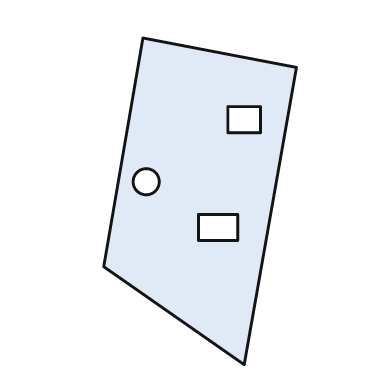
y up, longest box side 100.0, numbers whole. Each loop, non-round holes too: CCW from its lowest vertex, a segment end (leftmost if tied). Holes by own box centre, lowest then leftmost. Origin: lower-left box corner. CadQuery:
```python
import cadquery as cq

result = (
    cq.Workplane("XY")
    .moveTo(43.0, 0.0)
    .lineTo(59.0, 91.0)
    .lineTo(12.0, 100.0)
    .lineTo(0.0, 30.0)
    .close()
    .moveTo(29.0, 38.0)
    .lineTo(41.0, 38.0)
    .lineTo(41.0, 46.0)
    .lineTo(29.0, 46.0)
    .close()
    .moveTo(13.0, 56.0)
    .circle(4.0)
    .moveTo(38.0, 71.0)
    .lineTo(48.0, 71.0)
    .lineTo(48.0, 79.0)
    .lineTo(38.0, 79.0)
    .close()
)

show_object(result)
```